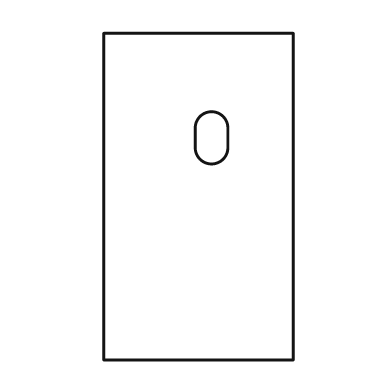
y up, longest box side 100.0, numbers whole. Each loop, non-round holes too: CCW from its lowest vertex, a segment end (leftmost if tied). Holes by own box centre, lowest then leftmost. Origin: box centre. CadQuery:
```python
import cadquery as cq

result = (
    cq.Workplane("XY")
    .moveTo(-29.0, -50.0)
    .lineTo(29.0, -50.0)
    .lineTo(29.0, 50.0)
    .lineTo(-29.0, 50.0)
    .close()
    .moveTo(-1.0, 15.0)
    .threePointArc((4.0, 10.0), (9.0, 15.0))
    .lineTo(9.0, 21.0)
    .threePointArc((4.0, 26.0), (-1.0, 21.0))
    .close()
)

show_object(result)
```